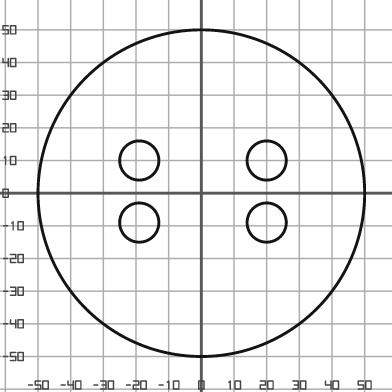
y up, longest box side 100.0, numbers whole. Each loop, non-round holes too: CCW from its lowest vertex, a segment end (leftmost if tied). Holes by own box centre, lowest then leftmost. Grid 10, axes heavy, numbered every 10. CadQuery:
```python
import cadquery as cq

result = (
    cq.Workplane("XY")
    .moveTo(0.0, 0.0)
    .circle(50.0)
    .moveTo(-19.0, -9.0)
    .circle(6.0)
    .moveTo(20.0, -9.0)
    .circle(6.0)
    .moveTo(-19.0, 10.0)
    .circle(6.0)
    .moveTo(20.0, 10.0)
    .circle(6.0)
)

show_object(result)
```